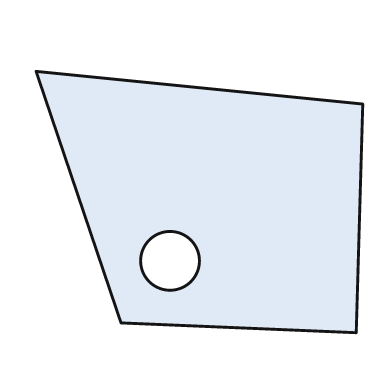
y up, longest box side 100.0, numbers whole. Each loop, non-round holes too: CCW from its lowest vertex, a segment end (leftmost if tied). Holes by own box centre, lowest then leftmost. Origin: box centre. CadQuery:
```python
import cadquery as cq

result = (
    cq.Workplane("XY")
    .moveTo(48.0, -40.0)
    .lineTo(50.0, 30.0)
    .lineTo(-50.0, 40.0)
    .lineTo(-24.0, -37.0)
    .close()
    .moveTo(-9.0, -18.0)
    .circle(9.0)
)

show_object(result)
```